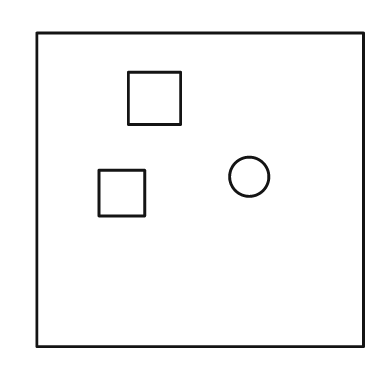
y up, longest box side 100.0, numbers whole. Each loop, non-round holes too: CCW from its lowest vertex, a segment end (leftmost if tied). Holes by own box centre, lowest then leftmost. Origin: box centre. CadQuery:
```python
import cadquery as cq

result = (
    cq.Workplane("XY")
    .moveTo(-50.0, -48.0)
    .lineTo(50.0, -48.0)
    .lineTo(50.0, 48.0)
    .lineTo(-50.0, 48.0)
    .close()
    .moveTo(-31.0, -8.0)
    .lineTo(-17.0, -8.0)
    .lineTo(-17.0, 6.0)
    .lineTo(-31.0, 6.0)
    .close()
    .moveTo(15.0, 4.0)
    .circle(6.0)
    .moveTo(-22.0, 20.0)
    .lineTo(-6.0, 20.0)
    .lineTo(-6.0, 36.0)
    .lineTo(-22.0, 36.0)
    .close()
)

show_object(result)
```